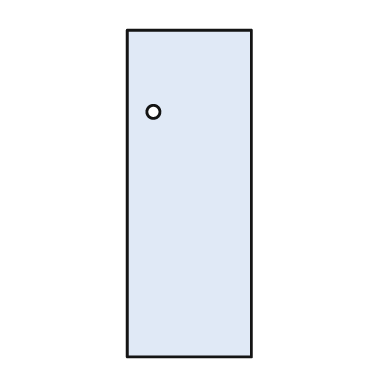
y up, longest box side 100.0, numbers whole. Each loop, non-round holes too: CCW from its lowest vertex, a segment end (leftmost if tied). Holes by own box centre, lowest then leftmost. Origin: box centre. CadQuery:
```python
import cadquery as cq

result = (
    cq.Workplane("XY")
    .moveTo(-19.0, -50.0)
    .lineTo(19.0, -50.0)
    .lineTo(19.0, 50.0)
    .lineTo(-19.0, 50.0)
    .close()
    .moveTo(-11.0, 25.0)
    .circle(2.0)
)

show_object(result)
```